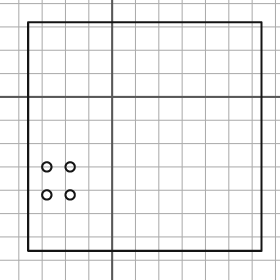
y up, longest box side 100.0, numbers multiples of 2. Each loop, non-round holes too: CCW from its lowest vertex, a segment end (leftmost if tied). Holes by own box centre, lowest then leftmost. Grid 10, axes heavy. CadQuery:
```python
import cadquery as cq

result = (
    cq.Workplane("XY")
    .moveTo(-36.0, -66.0)
    .lineTo(64.0, -66.0)
    .lineTo(64.0, 32.0)
    .lineTo(-36.0, 32.0)
    .close()
    .moveTo(-28.0, -42.0)
    .circle(2.0)
    .moveTo(-18.0, -42.0)
    .circle(2.0)
    .moveTo(-28.0, -30.0)
    .circle(2.0)
    .moveTo(-18.0, -30.0)
    .circle(2.0)
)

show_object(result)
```